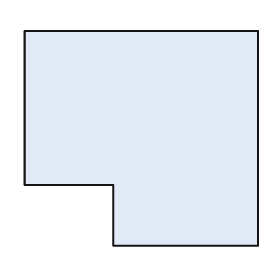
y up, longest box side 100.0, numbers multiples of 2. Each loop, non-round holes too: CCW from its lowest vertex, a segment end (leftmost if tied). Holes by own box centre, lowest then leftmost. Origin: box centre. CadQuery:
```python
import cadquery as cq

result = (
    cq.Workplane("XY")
    .moveTo(-12.0, -46.0)
    .lineTo(50.0, -46.0)
    .lineTo(50.0, 46.0)
    .lineTo(-50.0, 46.0)
    .lineTo(-50.0, -20.0)
    .lineTo(-12.0, -20.0)
    .close()
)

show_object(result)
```